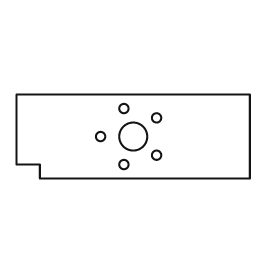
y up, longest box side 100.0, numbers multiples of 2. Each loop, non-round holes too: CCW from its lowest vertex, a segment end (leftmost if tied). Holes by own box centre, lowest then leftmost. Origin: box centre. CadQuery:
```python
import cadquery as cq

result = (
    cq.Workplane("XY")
    .moveTo(-40.0, -18.0)
    .lineTo(50.0, -18.0)
    .lineTo(50.0, 18.0)
    .lineTo(-50.0, 18.0)
    .lineTo(-50.0, -12.0)
    .lineTo(-40.0, -12.0)
    .close()
    .moveTo(-4.0, -12.0)
    .circle(2.0)
    .moveTo(10.0, -8.0)
    .circle(2.0)
    .moveTo(-14.0, 0.0)
    .circle(2.0)
    .moveTo(0.0, 0.0)
    .circle(6.0)
    .moveTo(10.0, 8.0)
    .circle(2.0)
    .moveTo(-4.0, 12.0)
    .circle(2.0)
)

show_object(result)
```